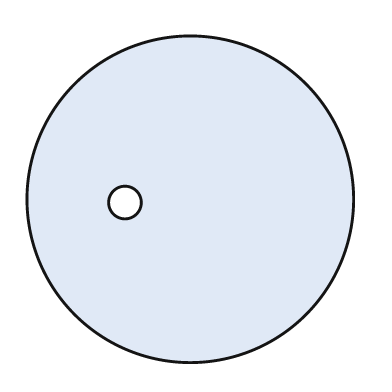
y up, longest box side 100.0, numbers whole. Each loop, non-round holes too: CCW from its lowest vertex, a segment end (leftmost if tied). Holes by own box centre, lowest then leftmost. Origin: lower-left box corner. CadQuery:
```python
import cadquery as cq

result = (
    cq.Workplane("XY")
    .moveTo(50.0, 50.0)
    .circle(50.0)
    .moveTo(30.0, 49.0)
    .circle(5.0)
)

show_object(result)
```